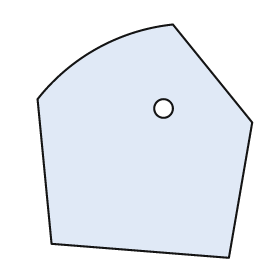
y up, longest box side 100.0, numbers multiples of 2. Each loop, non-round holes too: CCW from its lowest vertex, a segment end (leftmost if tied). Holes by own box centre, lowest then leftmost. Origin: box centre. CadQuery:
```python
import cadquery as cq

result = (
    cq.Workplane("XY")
    .moveTo(36.0, -50.0)
    .lineTo(46.0, 8.0)
    .lineTo(12.0, 50.0)
    .threePointArc((-20.0, 40.0), (-46.0, 18.0))
    .lineTo(-40.0, -44.0)
    .close()
    .moveTo(8.0, 14.0)
    .circle(4.0)
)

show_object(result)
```